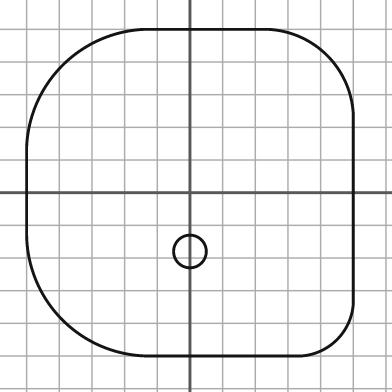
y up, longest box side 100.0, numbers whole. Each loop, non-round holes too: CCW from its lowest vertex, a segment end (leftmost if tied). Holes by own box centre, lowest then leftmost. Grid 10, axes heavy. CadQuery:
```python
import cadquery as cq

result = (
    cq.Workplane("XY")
    .moveTo(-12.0, -50.0)
    .lineTo(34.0, -50.0)
    .threePointArc((45.0, -45.0), (50.0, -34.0))
    .lineTo(50.0, 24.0)
    .threePointArc((42.0, 42.0), (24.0, 50.0))
    .lineTo(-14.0, 50.0)
    .threePointArc((-39.0, 39.0), (-50.0, 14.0))
    .lineTo(-50.0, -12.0)
    .threePointArc((-39.0, -39.0), (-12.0, -50.0))
    .close()
    .moveTo(0.0, -18.0)
    .circle(5.0)
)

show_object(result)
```